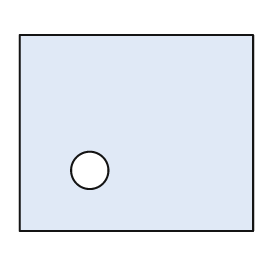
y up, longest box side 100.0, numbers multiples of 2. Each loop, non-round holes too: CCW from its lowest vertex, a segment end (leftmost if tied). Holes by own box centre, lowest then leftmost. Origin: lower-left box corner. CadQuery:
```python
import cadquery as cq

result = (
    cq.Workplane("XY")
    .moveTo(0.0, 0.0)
    .lineTo(100.0, 0.0)
    .lineTo(100.0, 84.0)
    .lineTo(0.0, 84.0)
    .close()
    .moveTo(30.0, 26.0)
    .circle(8.0)
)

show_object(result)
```